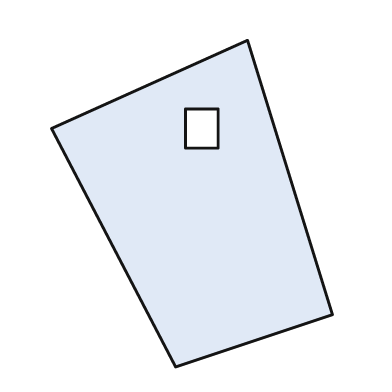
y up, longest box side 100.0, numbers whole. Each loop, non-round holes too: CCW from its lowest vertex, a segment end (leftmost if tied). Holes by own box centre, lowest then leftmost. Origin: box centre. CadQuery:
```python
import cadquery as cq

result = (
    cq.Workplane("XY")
    .moveTo(-5.0, -50.0)
    .lineTo(43.0, -34.0)
    .lineTo(17.0, 50.0)
    .lineTo(-43.0, 23.0)
    .close()
    .moveTo(-2.0, 17.0)
    .lineTo(8.0, 17.0)
    .lineTo(8.0, 29.0)
    .lineTo(-2.0, 29.0)
    .close()
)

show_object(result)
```